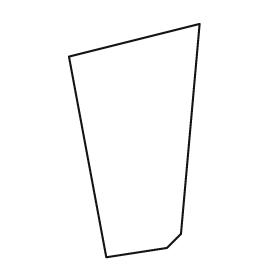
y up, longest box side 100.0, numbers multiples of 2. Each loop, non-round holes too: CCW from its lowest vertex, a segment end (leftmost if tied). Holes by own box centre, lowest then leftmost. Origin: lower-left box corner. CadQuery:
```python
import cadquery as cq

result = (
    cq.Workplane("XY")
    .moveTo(16.0, 0.0)
    .lineTo(42.0, 4.0)
    .lineTo(48.0, 10.0)
    .lineTo(56.0, 100.0)
    .lineTo(0.0, 86.0)
    .close()
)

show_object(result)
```